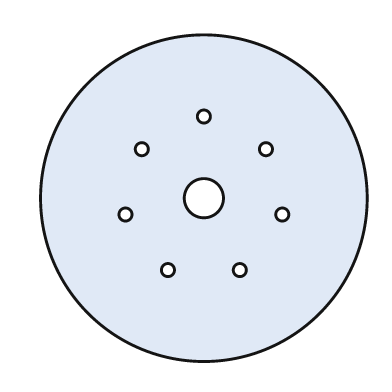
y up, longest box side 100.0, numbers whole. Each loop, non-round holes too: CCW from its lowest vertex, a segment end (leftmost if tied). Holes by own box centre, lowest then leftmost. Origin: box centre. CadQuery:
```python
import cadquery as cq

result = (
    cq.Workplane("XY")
    .moveTo(0.0, 0.0)
    .circle(50.0)
    .moveTo(-11.0, -22.0)
    .circle(2.0)
    .moveTo(11.0, -22.0)
    .circle(2.0)
    .moveTo(-24.0, -5.0)
    .circle(2.0)
    .moveTo(24.0, -5.0)
    .circle(2.0)
    .moveTo(0.0, 0.0)
    .circle(6.0)
    .moveTo(-19.0, 15.0)
    .circle(2.0)
    .moveTo(19.0, 15.0)
    .circle(2.0)
    .moveTo(0.0, 25.0)
    .circle(2.0)
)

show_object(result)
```